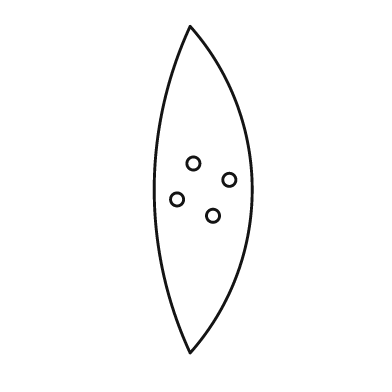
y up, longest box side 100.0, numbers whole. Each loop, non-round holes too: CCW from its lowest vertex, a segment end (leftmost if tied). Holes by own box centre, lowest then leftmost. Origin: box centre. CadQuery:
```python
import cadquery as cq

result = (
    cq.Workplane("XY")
    .moveTo(-4.0, -50.0)
    .threePointArc((15.0, 0.0), (-4.0, 50.0))
    .threePointArc((-15.0, 0.0), (-4.0, -50.0))
    .close()
    .moveTo(3.0, -8.0)
    .circle(2.0)
    .moveTo(-8.0, -3.0)
    .circle(2.0)
    .moveTo(8.0, 3.0)
    .circle(2.0)
    .moveTo(-3.0, 8.0)
    .circle(2.0)
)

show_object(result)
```